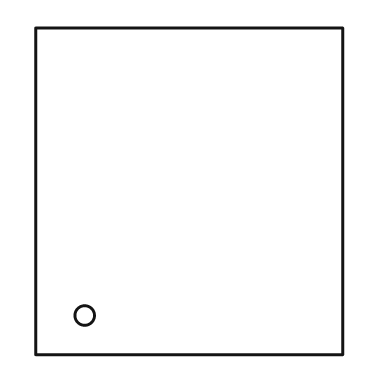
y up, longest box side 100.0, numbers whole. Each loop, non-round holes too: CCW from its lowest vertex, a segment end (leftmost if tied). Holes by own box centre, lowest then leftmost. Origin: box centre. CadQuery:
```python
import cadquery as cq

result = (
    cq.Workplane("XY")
    .moveTo(-47.0, -50.0)
    .lineTo(47.0, -50.0)
    .lineTo(47.0, 50.0)
    .lineTo(-47.0, 50.0)
    .close()
    .moveTo(-32.0, -38.0)
    .circle(3.0)
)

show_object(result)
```